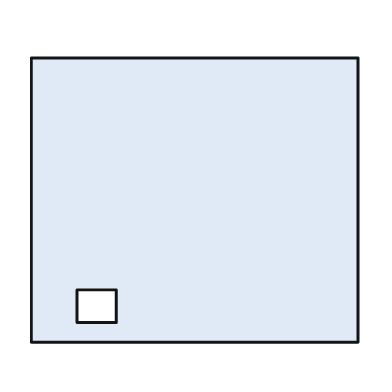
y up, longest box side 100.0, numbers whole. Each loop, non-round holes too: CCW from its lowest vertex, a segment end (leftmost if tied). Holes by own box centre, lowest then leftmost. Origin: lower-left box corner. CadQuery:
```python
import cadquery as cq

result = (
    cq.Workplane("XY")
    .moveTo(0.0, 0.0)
    .lineTo(100.0, 0.0)
    .lineTo(100.0, 87.0)
    .lineTo(0.0, 87.0)
    .close()
    .moveTo(14.0, 6.0)
    .lineTo(26.0, 6.0)
    .lineTo(26.0, 16.0)
    .lineTo(14.0, 16.0)
    .close()
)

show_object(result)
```